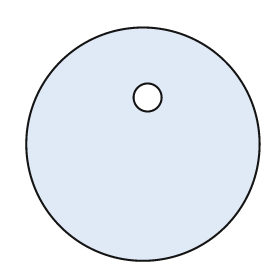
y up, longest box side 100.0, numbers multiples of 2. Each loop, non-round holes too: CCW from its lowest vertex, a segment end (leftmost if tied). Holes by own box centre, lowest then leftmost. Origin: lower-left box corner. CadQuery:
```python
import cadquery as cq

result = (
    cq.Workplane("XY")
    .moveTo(50.0, 50.0)
    .circle(50.0)
    .moveTo(52.0, 70.0)
    .circle(6.0)
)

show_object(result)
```